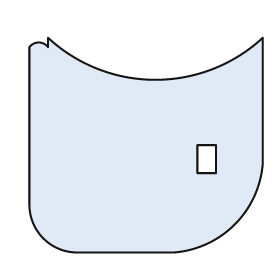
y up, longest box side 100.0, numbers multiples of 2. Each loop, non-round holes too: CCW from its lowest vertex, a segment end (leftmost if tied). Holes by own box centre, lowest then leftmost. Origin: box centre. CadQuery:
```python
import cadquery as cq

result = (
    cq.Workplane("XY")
    .moveTo(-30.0, -46.0)
    .lineTo(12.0, -46.0)
    .threePointArc((38.0, -34.0), (50.0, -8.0))
    .lineTo(50.0, 46.0)
    .threePointArc((4.0, 28.0), (-42.0, 46.0))
    .lineTo(-42.0, 42.0)
    .threePointArc((-46.0, 44.0), (-50.0, 42.0))
    .lineTo(-50.0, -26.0)
    .threePointArc((-44.0, -40.0), (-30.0, -46.0))
    .close()
    .moveTo(22.0, -12.0)
    .lineTo(30.0, -12.0)
    .lineTo(30.0, 0.0)
    .lineTo(22.0, 0.0)
    .close()
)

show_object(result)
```